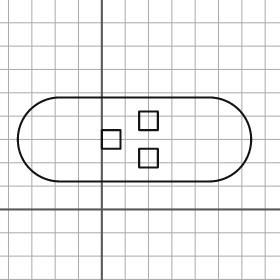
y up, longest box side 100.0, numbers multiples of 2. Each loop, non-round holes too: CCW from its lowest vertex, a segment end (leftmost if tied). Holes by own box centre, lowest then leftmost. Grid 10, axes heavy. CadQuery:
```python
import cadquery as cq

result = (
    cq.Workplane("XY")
    .moveTo(-18.0, 12.0)
    .lineTo(46.0, 12.0)
    .threePointArc((64.0, 30.0), (46.0, 48.0))
    .lineTo(-18.0, 48.0)
    .threePointArc((-36.0, 30.0), (-18.0, 12.0))
    .close()
    .moveTo(16.0, 18.0)
    .lineTo(24.0, 18.0)
    .lineTo(24.0, 26.0)
    .lineTo(16.0, 26.0)
    .close()
    .moveTo(0.0, 26.0)
    .lineTo(8.0, 26.0)
    .lineTo(8.0, 34.0)
    .lineTo(0.0, 34.0)
    .close()
    .moveTo(16.0, 34.0)
    .lineTo(24.0, 34.0)
    .lineTo(24.0, 42.0)
    .lineTo(16.0, 42.0)
    .close()
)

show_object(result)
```